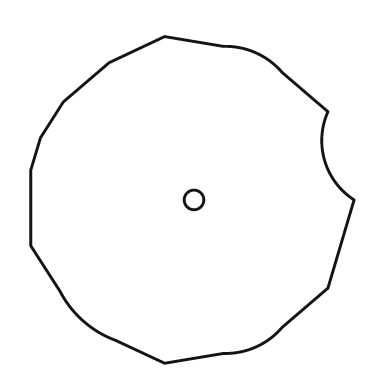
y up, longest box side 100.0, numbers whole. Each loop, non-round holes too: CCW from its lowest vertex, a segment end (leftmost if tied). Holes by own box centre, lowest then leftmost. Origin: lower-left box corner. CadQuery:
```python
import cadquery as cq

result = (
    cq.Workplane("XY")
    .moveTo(41.0, 0.0)
    .lineTo(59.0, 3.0)
    .threePointArc((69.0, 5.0), (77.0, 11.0))
    .lineTo(91.0, 23.0)
    .lineTo(99.0, 50.0)
    .threePointArc((90.0, 62.0), (91.0, 77.0))
    .lineTo(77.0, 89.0)
    .threePointArc((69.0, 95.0), (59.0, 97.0))
    .lineTo(41.0, 100.0)
    .lineTo(24.0, 92.0)
    .lineTo(10.0, 80.0)
    .lineTo(3.0, 69.0)
    .lineTo(0.0, 59.0)
    .lineTo(0.0, 36.0)
    .lineTo(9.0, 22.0)
    .threePointArc((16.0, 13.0), (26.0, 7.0))
    .close()
    .moveTo(50.0, 50.0)
    .circle(3.0)
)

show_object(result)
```